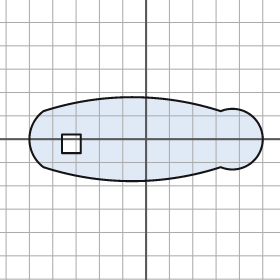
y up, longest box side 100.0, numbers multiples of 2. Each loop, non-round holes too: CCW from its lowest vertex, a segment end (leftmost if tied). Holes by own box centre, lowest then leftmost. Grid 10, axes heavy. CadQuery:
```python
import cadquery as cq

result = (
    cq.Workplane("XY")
    .moveTo(-44.0, -12.0)
    .threePointArc((-6.0, -18.0), (32.0, -12.0))
    .threePointArc((50.0, 0.0), (32.0, 12.0))
    .threePointArc((-6.0, 18.0), (-44.0, 12.0))
    .threePointArc((-50.0, 0.0), (-44.0, -12.0))
    .close()
    .moveTo(-36.0, -6.0)
    .lineTo(-28.0, -6.0)
    .lineTo(-28.0, 2.0)
    .lineTo(-36.0, 2.0)
    .close()
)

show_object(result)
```